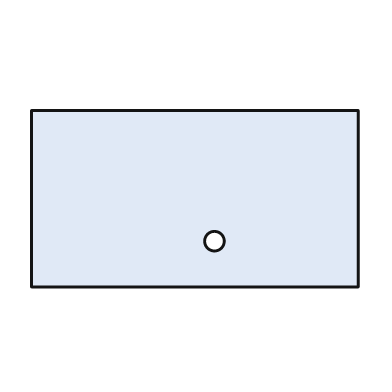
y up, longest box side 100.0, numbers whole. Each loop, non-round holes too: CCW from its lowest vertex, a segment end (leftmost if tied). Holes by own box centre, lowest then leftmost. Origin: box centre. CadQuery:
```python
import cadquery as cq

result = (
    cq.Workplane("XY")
    .moveTo(-50.0, -27.0)
    .lineTo(50.0, -27.0)
    .lineTo(50.0, 27.0)
    .lineTo(-50.0, 27.0)
    .close()
    .moveTo(6.0, -13.0)
    .circle(3.0)
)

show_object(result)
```